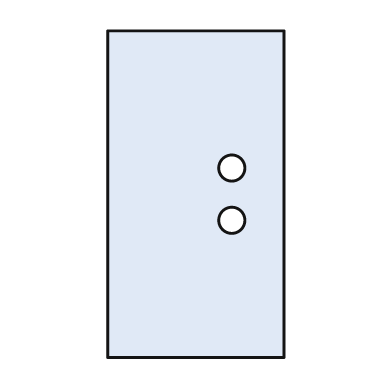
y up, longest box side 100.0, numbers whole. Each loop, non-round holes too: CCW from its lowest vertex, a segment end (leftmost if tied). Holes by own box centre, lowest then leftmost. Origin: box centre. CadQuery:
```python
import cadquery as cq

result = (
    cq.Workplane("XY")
    .moveTo(-27.0, -50.0)
    .lineTo(27.0, -50.0)
    .lineTo(27.0, 50.0)
    .lineTo(-27.0, 50.0)
    .close()
    .moveTo(11.0, -8.0)
    .circle(4.0)
    .moveTo(11.0, 8.0)
    .circle(4.0)
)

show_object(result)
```